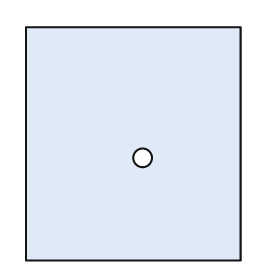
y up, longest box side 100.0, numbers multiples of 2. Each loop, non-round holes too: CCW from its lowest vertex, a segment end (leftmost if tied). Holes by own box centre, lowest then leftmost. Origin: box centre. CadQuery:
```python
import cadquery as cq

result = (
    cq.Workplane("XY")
    .moveTo(-46.0, -50.0)
    .lineTo(46.0, -50.0)
    .lineTo(46.0, 50.0)
    .lineTo(-46.0, 50.0)
    .close()
    .moveTo(4.0, -6.0)
    .circle(4.0)
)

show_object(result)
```